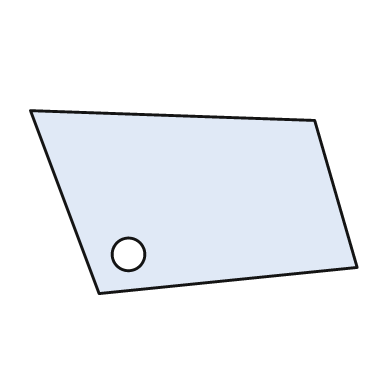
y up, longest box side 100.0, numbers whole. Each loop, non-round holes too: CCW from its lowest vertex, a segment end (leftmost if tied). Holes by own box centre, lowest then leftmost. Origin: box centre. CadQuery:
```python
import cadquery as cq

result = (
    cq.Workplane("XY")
    .moveTo(-29.0, -28.0)
    .lineTo(50.0, -20.0)
    .lineTo(37.0, 25.0)
    .lineTo(-50.0, 28.0)
    .close()
    .moveTo(-20.0, -16.0)
    .circle(5.0)
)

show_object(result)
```